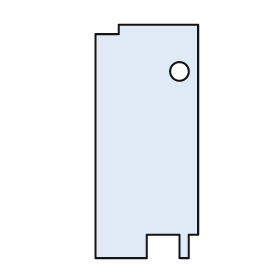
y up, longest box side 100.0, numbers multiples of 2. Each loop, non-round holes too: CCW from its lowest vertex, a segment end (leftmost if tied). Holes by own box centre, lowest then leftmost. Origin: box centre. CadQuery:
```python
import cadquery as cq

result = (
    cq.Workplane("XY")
    .moveTo(-22.0, -50.0)
    .lineTo(0.0, -50.0)
    .lineTo(0.0, -40.0)
    .lineTo(14.0, -40.0)
    .lineTo(14.0, -50.0)
    .lineTo(18.0, -50.0)
    .lineTo(18.0, -40.0)
    .lineTo(22.0, -40.0)
    .lineTo(22.0, 50.0)
    .lineTo(-12.0, 50.0)
    .lineTo(-12.0, 46.0)
    .lineTo(-22.0, 46.0)
    .close()
    .moveTo(14.0, 30.0)
    .circle(4.0)
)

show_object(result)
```